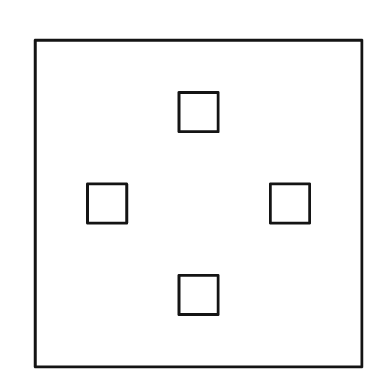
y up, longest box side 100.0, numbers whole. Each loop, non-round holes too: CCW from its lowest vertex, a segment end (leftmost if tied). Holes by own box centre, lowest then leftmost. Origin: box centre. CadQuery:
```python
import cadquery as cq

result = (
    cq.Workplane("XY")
    .moveTo(-50.0, -50.0)
    .lineTo(50.0, -50.0)
    .lineTo(50.0, 50.0)
    .lineTo(-50.0, 50.0)
    .close()
    .moveTo(-6.0, -34.0)
    .lineTo(6.0, -34.0)
    .lineTo(6.0, -22.0)
    .lineTo(-6.0, -22.0)
    .close()
    .moveTo(-34.0, -6.0)
    .lineTo(-22.0, -6.0)
    .lineTo(-22.0, 6.0)
    .lineTo(-34.0, 6.0)
    .close()
    .moveTo(22.0, -6.0)
    .lineTo(34.0, -6.0)
    .lineTo(34.0, 6.0)
    .lineTo(22.0, 6.0)
    .close()
    .moveTo(-6.0, 22.0)
    .lineTo(6.0, 22.0)
    .lineTo(6.0, 34.0)
    .lineTo(-6.0, 34.0)
    .close()
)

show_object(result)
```